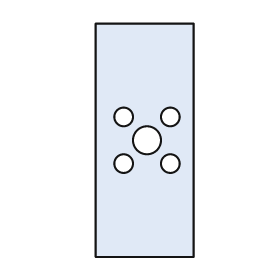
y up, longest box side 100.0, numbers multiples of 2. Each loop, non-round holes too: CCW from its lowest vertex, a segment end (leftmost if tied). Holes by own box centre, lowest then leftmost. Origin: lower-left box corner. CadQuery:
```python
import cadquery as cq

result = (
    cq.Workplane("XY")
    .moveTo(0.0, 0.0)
    .lineTo(42.0, 0.0)
    .lineTo(42.0, 100.0)
    .lineTo(0.0, 100.0)
    .close()
    .moveTo(12.0, 40.0)
    .circle(4.0)
    .moveTo(32.0, 40.0)
    .circle(4.0)
    .moveTo(22.0, 50.0)
    .circle(6.0)
    .moveTo(12.0, 60.0)
    .circle(4.0)
    .moveTo(32.0, 60.0)
    .circle(4.0)
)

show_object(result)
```